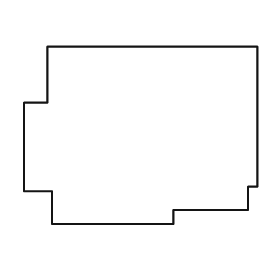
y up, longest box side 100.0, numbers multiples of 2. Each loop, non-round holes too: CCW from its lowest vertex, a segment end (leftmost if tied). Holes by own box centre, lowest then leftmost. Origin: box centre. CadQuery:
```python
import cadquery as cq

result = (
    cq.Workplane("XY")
    .moveTo(-38.0, -38.0)
    .lineTo(14.0, -38.0)
    .lineTo(14.0, -32.0)
    .lineTo(46.0, -32.0)
    .lineTo(46.0, -22.0)
    .lineTo(50.0, -22.0)
    .lineTo(50.0, 38.0)
    .lineTo(-40.0, 38.0)
    .lineTo(-40.0, 14.0)
    .lineTo(-50.0, 14.0)
    .lineTo(-50.0, -24.0)
    .lineTo(-38.0, -24.0)
    .close()
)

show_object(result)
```